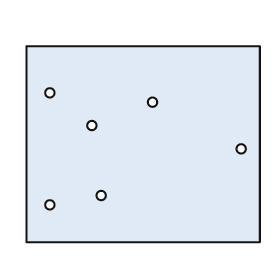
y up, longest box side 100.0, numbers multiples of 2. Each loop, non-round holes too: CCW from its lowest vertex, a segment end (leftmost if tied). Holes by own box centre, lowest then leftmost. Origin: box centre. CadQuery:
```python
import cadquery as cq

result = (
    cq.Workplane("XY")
    .moveTo(-50.0, -42.0)
    .lineTo(50.0, -42.0)
    .lineTo(50.0, 42.0)
    .lineTo(-50.0, 42.0)
    .close()
    .moveTo(-40.0, -26.0)
    .circle(2.0)
    .moveTo(-18.0, -22.0)
    .circle(2.0)
    .moveTo(42.0, -2.0)
    .circle(2.0)
    .moveTo(-22.0, 8.0)
    .circle(2.0)
    .moveTo(4.0, 18.0)
    .circle(2.0)
    .moveTo(-40.0, 22.0)
    .circle(2.0)
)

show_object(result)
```